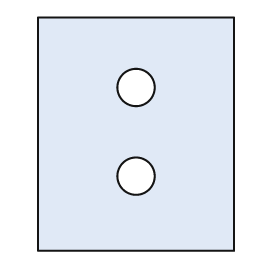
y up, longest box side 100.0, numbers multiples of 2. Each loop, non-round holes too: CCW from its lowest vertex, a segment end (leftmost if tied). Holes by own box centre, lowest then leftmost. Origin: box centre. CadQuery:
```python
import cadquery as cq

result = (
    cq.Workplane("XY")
    .moveTo(-42.0, -50.0)
    .lineTo(42.0, -50.0)
    .lineTo(42.0, 50.0)
    .lineTo(-42.0, 50.0)
    .close()
    .moveTo(0.0, -18.0)
    .circle(8.0)
    .moveTo(0.0, 20.0)
    .circle(8.0)
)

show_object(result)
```